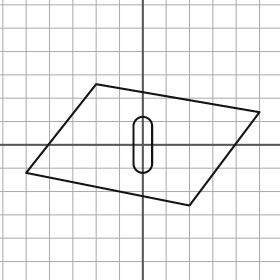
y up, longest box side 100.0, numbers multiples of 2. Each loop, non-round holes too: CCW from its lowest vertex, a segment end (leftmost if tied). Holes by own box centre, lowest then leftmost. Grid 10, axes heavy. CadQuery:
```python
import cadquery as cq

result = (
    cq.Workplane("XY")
    .moveTo(20.0, -26.0)
    .lineTo(50.0, 14.0)
    .lineTo(-20.0, 26.0)
    .lineTo(-50.0, -12.0)
    .close()
    .moveTo(-4.0, -8.0)
    .threePointArc((0.0, -12.0), (4.0, -8.0))
    .lineTo(4.0, 8.0)
    .threePointArc((0.0, 12.0), (-4.0, 8.0))
    .close()
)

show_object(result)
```